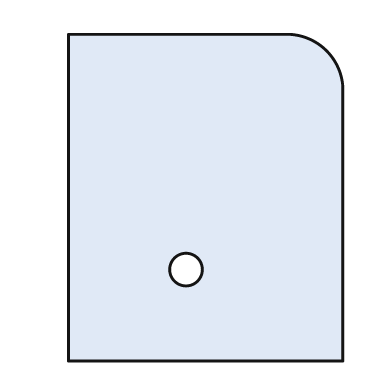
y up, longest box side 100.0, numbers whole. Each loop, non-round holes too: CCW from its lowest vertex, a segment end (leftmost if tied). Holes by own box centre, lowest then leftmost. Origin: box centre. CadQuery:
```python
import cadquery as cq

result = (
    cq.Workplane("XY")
    .moveTo(-42.0, -50.0)
    .lineTo(42.0, -50.0)
    .lineTo(42.0, 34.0)
    .threePointArc((37.0, 45.0), (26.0, 50.0))
    .lineTo(-42.0, 50.0)
    .close()
    .moveTo(-6.0, -22.0)
    .circle(5.0)
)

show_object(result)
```